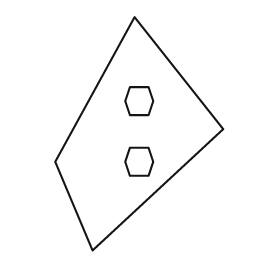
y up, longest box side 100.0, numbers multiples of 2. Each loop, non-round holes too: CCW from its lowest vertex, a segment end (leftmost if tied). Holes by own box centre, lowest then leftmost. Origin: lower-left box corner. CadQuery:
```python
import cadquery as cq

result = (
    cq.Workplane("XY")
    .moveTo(16.0, 0.0)
    .lineTo(72.0, 52.0)
    .lineTo(34.0, 100.0)
    .lineTo(0.0, 38.0)
    .close()
    .moveTo(32.0, 32.0)
    .lineTo(40.0, 32.0)
    .lineTo(42.0, 38.0)
    .lineTo(40.0, 44.0)
    .lineTo(32.0, 44.0)
    .lineTo(30.0, 38.0)
    .close()
    .moveTo(32.0, 58.0)
    .lineTo(40.0, 58.0)
    .lineTo(42.0, 64.0)
    .lineTo(40.0, 70.0)
    .lineTo(32.0, 70.0)
    .lineTo(30.0, 64.0)
    .close()
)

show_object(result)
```